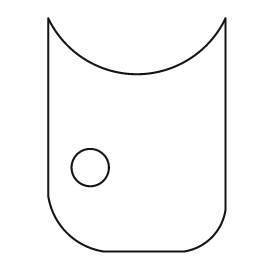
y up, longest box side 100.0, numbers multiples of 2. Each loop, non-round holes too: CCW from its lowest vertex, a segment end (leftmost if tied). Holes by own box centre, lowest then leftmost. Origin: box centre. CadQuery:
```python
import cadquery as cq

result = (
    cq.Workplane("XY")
    .moveTo(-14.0, -50.0)
    .lineTo(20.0, -50.0)
    .threePointArc((32.0, -44.0), (38.0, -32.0))
    .lineTo(38.0, 50.0)
    .threePointArc((0.0, 26.0), (-38.0, 50.0))
    .lineTo(-38.0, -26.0)
    .threePointArc((-30.0, -42.0), (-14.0, -50.0))
    .close()
    .moveTo(-20.0, -14.0)
    .circle(8.0)
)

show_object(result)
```